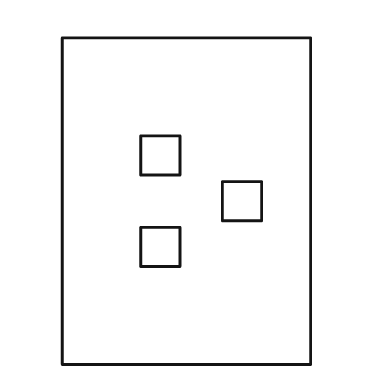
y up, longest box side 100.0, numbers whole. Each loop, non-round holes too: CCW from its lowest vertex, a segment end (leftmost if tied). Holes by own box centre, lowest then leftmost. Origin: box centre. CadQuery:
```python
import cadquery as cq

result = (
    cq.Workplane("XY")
    .moveTo(-38.0, -50.0)
    .lineTo(38.0, -50.0)
    .lineTo(38.0, 50.0)
    .lineTo(-38.0, 50.0)
    .close()
    .moveTo(-14.0, -20.0)
    .lineTo(-2.0, -20.0)
    .lineTo(-2.0, -8.0)
    .lineTo(-14.0, -8.0)
    .close()
    .moveTo(11.0, -6.0)
    .lineTo(23.0, -6.0)
    .lineTo(23.0, 6.0)
    .lineTo(11.0, 6.0)
    .close()
    .moveTo(-14.0, 8.0)
    .lineTo(-2.0, 8.0)
    .lineTo(-2.0, 20.0)
    .lineTo(-14.0, 20.0)
    .close()
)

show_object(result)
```